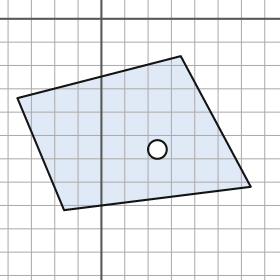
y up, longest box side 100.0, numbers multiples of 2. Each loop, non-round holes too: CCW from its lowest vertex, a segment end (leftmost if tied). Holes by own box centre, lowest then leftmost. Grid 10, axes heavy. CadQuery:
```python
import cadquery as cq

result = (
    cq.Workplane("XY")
    .moveTo(-16.0, -82.0)
    .lineTo(64.0, -72.0)
    .lineTo(34.0, -16.0)
    .lineTo(-36.0, -34.0)
    .close()
    .moveTo(24.0, -56.0)
    .circle(4.0)
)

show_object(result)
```